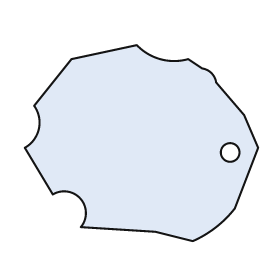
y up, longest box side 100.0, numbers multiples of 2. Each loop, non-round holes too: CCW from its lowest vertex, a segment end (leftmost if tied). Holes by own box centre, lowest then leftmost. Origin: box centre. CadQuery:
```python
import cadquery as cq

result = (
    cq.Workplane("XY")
    .moveTo(22.0, -42.0)
    .threePointArc((32.0, -36.0), (40.0, -28.0))
    .lineTo(50.0, -2.0)
    .lineTo(44.0, 12.0)
    .lineTo(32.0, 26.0)
    .threePointArc((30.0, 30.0), (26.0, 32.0))
    .lineTo(20.0, 36.0)
    .threePointArc((8.0, 36.0), (-2.0, 42.0))
    .lineTo(-30.0, 36.0)
    .lineTo(-46.0, 16.0)
    .threePointArc((-44.0, 6.0), (-50.0, -2.0))
    .lineTo(-38.0, -22.0)
    .threePointArc((-26.0, -24.0), (-26.0, -36.0))
    .lineTo(6.0, -38.0)
    .close()
    .moveTo(38.0, -4.0)
    .circle(4.0)
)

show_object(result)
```